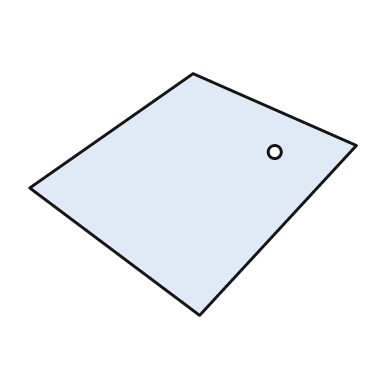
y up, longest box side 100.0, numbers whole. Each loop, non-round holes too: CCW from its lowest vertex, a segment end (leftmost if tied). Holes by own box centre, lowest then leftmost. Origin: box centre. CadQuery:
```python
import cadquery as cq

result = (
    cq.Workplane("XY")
    .moveTo(2.0, -37.0)
    .lineTo(50.0, 15.0)
    .lineTo(0.0, 37.0)
    .lineTo(-50.0, 2.0)
    .close()
    .moveTo(25.0, 13.0)
    .circle(2.0)
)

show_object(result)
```